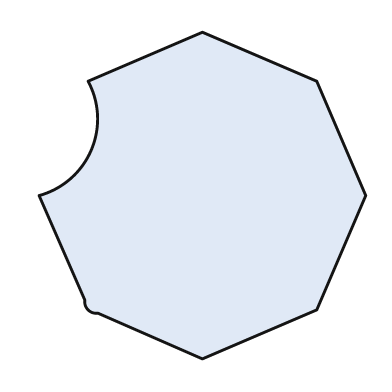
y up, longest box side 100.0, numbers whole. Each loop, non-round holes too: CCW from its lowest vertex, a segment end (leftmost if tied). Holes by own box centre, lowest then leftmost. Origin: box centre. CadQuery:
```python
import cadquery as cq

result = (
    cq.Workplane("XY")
    .moveTo(0.0, -50.0)
    .lineTo(35.0, -35.0)
    .lineTo(50.0, 0.0)
    .lineTo(35.0, 35.0)
    .lineTo(0.0, 50.0)
    .lineTo(-35.0, 35.0)
    .threePointArc((-34.0, 14.0), (-50.0, 0.0))
    .lineTo(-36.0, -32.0)
    .threePointArc((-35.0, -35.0), (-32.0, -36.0))
    .close()
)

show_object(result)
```